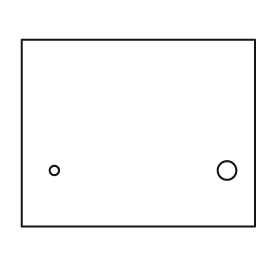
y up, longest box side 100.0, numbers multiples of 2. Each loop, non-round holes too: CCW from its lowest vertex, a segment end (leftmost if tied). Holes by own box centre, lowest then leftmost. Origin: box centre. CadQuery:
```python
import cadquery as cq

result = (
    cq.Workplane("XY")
    .moveTo(-50.0, -40.0)
    .lineTo(50.0, -40.0)
    .lineTo(50.0, 40.0)
    .lineTo(-50.0, 40.0)
    .close()
    .moveTo(-36.0, -16.0)
    .circle(2.0)
    .moveTo(38.0, -16.0)
    .circle(4.0)
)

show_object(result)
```